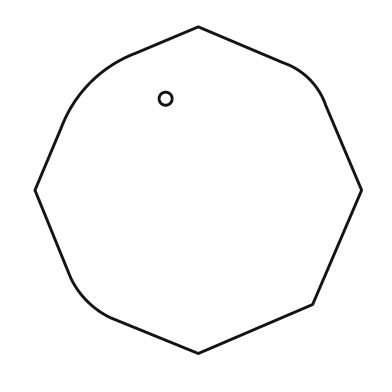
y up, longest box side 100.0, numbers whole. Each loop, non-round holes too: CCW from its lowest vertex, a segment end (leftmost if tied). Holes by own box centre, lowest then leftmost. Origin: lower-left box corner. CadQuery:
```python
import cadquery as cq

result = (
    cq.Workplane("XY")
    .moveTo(50.0, 0.0)
    .lineTo(85.0, 15.0)
    .lineTo(100.0, 50.0)
    .lineTo(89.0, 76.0)
    .threePointArc((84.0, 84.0), (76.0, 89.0))
    .lineTo(50.0, 100.0)
    .lineTo(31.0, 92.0)
    .threePointArc((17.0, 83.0), (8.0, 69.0))
    .lineTo(0.0, 50.0)
    .lineTo(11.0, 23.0)
    .threePointArc((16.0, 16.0), (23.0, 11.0))
    .close()
    .moveTo(40.0, 78.0)
    .circle(2.0)
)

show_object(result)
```